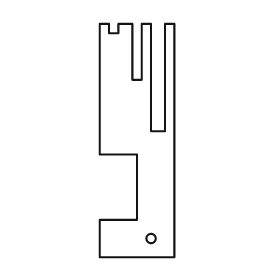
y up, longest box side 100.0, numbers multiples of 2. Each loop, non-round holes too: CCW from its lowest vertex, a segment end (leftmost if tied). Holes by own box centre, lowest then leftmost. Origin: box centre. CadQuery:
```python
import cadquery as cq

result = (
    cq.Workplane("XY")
    .moveTo(-16.0, -50.0)
    .lineTo(16.0, -50.0)
    .lineTo(16.0, 50.0)
    .lineTo(12.0, 50.0)
    .lineTo(12.0, 4.0)
    .lineTo(6.0, 4.0)
    .lineTo(6.0, 50.0)
    .lineTo(2.0, 50.0)
    .lineTo(2.0, 26.0)
    .lineTo(-2.0, 26.0)
    .lineTo(-2.0, 50.0)
    .lineTo(-8.0, 50.0)
    .lineTo(-8.0, 46.0)
    .lineTo(-12.0, 46.0)
    .lineTo(-12.0, 50.0)
    .lineTo(-16.0, 50.0)
    .lineTo(-16.0, -6.0)
    .lineTo(0.0, -6.0)
    .lineTo(0.0, -34.0)
    .lineTo(-16.0, -34.0)
    .close()
    .moveTo(6.0, -42.0)
    .circle(2.0)
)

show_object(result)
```